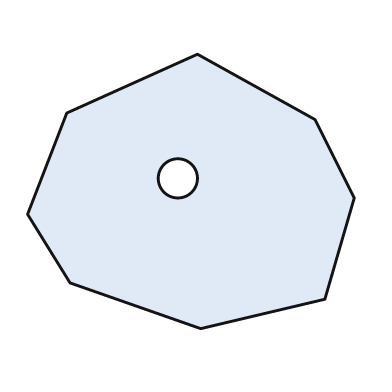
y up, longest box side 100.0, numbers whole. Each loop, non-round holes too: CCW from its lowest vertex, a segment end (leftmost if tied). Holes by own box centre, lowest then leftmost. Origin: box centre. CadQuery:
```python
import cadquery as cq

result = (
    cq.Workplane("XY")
    .moveTo(3.0, -42.0)
    .lineTo(41.0, -33.0)
    .lineTo(50.0, -2.0)
    .lineTo(38.0, 22.0)
    .lineTo(2.0, 42.0)
    .lineTo(-38.0, 24.0)
    .lineTo(-50.0, -7.0)
    .lineTo(-37.0, -28.0)
    .close()
    .moveTo(-4.0, 4.0)
    .circle(6.0)
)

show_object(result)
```